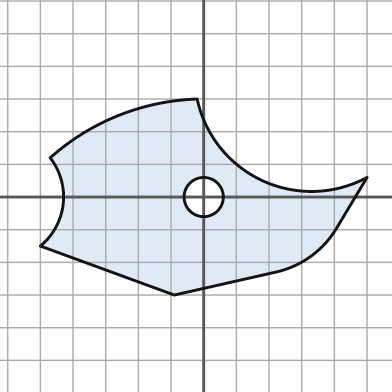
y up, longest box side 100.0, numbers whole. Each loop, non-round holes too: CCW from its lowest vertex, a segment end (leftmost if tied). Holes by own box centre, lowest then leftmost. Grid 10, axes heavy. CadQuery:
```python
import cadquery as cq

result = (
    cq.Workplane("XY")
    .moveTo(-9.0, -30.0)
    .lineTo(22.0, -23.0)
    .threePointArc((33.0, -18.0), (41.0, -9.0))
    .lineTo(50.0, 6.0)
    .threePointArc((18.0, 5.0), (-2.0, 30.0))
    .threePointArc((-26.0, 25.0), (-47.0, 12.0))
    .threePointArc((-43.0, -2.0), (-50.0, -15.0))
    .close()
    .moveTo(0.0, 0.0)
    .circle(6.0)
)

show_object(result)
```